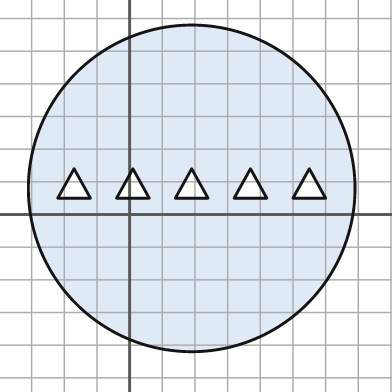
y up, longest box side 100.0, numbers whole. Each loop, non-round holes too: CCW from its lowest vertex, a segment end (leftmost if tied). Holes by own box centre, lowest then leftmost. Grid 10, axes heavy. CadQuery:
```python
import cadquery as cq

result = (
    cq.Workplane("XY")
    .moveTo(19.0, 8.0)
    .circle(50.0)
    .moveTo(-22.0, 5.0)
    .lineTo(-12.0, 5.0)
    .lineTo(-17.0, 14.0)
    .close()
    .moveTo(-4.0, 5.0)
    .lineTo(6.0, 5.0)
    .lineTo(1.0, 14.0)
    .close()
    .moveTo(14.0, 5.0)
    .lineTo(24.0, 5.0)
    .lineTo(19.0, 14.0)
    .close()
    .moveTo(32.0, 5.0)
    .lineTo(42.0, 5.0)
    .lineTo(37.0, 14.0)
    .close()
    .moveTo(50.0, 5.0)
    .lineTo(60.0, 5.0)
    .lineTo(55.0, 14.0)
    .close()
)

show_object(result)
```